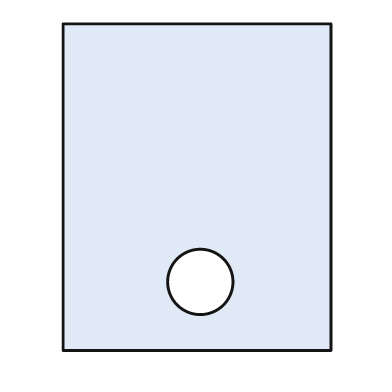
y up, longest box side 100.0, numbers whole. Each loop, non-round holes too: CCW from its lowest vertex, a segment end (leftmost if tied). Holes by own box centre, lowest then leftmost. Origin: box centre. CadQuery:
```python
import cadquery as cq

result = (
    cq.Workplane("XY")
    .moveTo(-41.0, -50.0)
    .lineTo(41.0, -50.0)
    .lineTo(41.0, 50.0)
    .lineTo(-41.0, 50.0)
    .close()
    .moveTo(1.0, -29.0)
    .circle(10.0)
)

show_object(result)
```